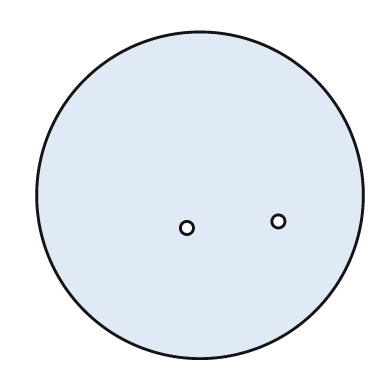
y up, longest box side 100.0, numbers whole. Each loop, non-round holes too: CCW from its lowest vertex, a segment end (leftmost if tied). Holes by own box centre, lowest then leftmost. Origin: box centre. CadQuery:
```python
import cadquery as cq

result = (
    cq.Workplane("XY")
    .moveTo(0.0, 0.0)
    .circle(50.0)
    .moveTo(-4.0, -10.0)
    .circle(2.0)
    .moveTo(24.0, -8.0)
    .circle(2.0)
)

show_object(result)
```